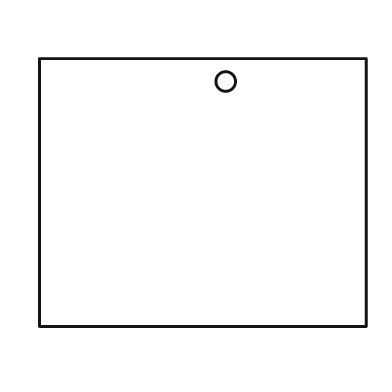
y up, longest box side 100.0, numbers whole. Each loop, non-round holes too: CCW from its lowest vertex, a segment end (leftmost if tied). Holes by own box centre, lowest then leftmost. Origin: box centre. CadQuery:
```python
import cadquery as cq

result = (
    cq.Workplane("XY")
    .moveTo(-50.0, -41.0)
    .lineTo(50.0, -41.0)
    .lineTo(50.0, 41.0)
    .lineTo(-50.0, 41.0)
    .close()
    .moveTo(7.0, 34.0)
    .circle(3.0)
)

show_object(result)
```